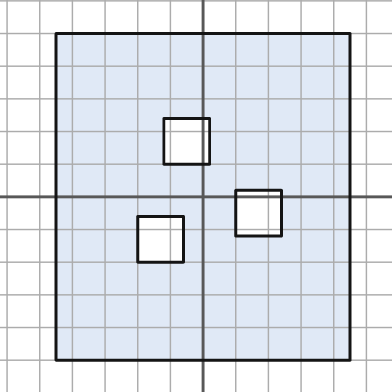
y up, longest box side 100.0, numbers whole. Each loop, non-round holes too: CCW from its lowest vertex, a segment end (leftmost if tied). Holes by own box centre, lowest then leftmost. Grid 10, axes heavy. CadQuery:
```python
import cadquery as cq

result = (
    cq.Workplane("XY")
    .moveTo(-45.0, -50.0)
    .lineTo(45.0, -50.0)
    .lineTo(45.0, 50.0)
    .lineTo(-45.0, 50.0)
    .close()
    .moveTo(-20.0, -20.0)
    .lineTo(-6.0, -20.0)
    .lineTo(-6.0, -6.0)
    .lineTo(-20.0, -6.0)
    .close()
    .moveTo(10.0, -12.0)
    .lineTo(24.0, -12.0)
    .lineTo(24.0, 2.0)
    .lineTo(10.0, 2.0)
    .close()
    .moveTo(-12.0, 10.0)
    .lineTo(2.0, 10.0)
    .lineTo(2.0, 24.0)
    .lineTo(-12.0, 24.0)
    .close()
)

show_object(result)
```